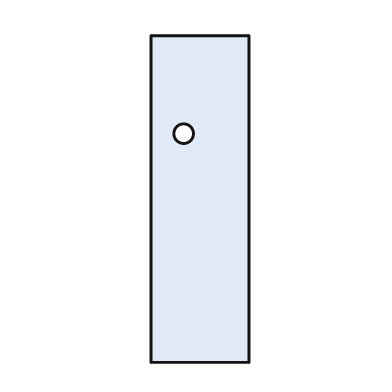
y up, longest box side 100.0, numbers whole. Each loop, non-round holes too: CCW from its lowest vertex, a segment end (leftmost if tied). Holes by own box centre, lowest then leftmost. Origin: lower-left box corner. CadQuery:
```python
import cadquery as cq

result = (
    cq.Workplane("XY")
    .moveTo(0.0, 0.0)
    .lineTo(30.0, 0.0)
    .lineTo(30.0, 100.0)
    .lineTo(0.0, 100.0)
    .close()
    .moveTo(10.0, 70.0)
    .circle(3.0)
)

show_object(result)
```